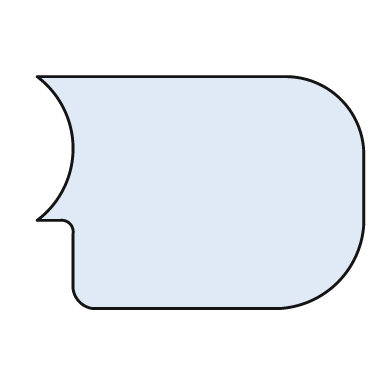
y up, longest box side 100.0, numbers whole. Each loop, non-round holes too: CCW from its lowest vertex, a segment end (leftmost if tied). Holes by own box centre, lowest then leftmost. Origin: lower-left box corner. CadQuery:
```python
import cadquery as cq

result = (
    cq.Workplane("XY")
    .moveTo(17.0, 0.0)
    .lineTo(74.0, 0.0)
    .threePointArc((92.0, 8.0), (100.0, 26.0))
    .lineTo(100.0, 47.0)
    .threePointArc((93.0, 64.0), (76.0, 71.0))
    .lineTo(0.0, 71.0)
    .threePointArc((11.0, 49.0), (0.0, 27.0))
    .lineTo(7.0, 27.0)
    .threePointArc((10.0, 26.0), (11.0, 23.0))
    .lineTo(11.0, 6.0)
    .threePointArc((13.0, 2.0), (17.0, 0.0))
    .close()
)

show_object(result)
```